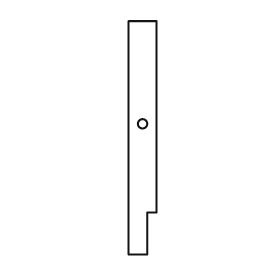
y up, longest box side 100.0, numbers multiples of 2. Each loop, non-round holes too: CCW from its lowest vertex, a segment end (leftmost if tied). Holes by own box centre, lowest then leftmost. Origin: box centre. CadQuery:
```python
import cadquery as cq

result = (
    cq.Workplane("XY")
    .moveTo(-6.0, -50.0)
    .lineTo(2.0, -50.0)
    .lineTo(2.0, -32.0)
    .lineTo(6.0, -32.0)
    .lineTo(6.0, 50.0)
    .lineTo(-6.0, 50.0)
    .close()
    .moveTo(0.0, 6.0)
    .circle(2.0)
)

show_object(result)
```